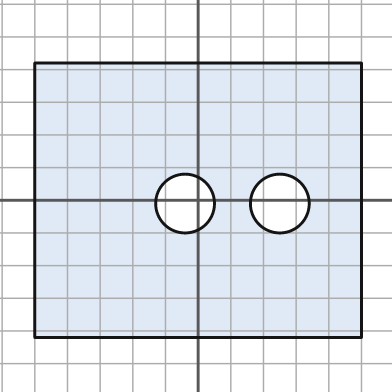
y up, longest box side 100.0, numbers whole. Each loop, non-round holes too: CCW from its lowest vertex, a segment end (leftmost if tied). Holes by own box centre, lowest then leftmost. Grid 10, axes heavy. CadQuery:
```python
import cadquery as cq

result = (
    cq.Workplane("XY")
    .moveTo(-50.0, -42.0)
    .lineTo(50.0, -42.0)
    .lineTo(50.0, 42.0)
    .lineTo(-50.0, 42.0)
    .close()
    .moveTo(-4.0, -1.0)
    .circle(9.0)
    .moveTo(25.0, -1.0)
    .circle(9.0)
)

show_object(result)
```